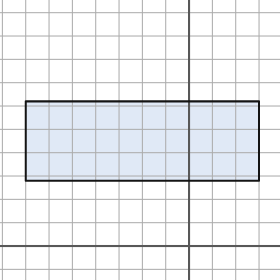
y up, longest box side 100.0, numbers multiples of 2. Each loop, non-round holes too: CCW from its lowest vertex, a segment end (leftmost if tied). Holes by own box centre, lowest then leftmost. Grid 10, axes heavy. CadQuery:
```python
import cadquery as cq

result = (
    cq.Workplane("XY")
    .moveTo(-70.0, 28.0)
    .lineTo(30.0, 28.0)
    .lineTo(30.0, 62.0)
    .lineTo(-70.0, 62.0)
    .close()
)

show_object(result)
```